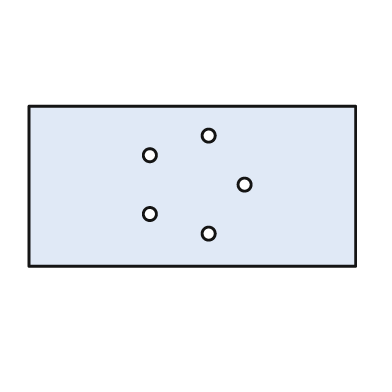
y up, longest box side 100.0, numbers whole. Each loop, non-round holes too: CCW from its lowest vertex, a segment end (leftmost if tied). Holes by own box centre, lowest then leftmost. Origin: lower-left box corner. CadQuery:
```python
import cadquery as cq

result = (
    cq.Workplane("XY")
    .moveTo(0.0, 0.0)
    .lineTo(100.0, 0.0)
    .lineTo(100.0, 49.0)
    .lineTo(0.0, 49.0)
    .close()
    .moveTo(55.0, 10.0)
    .circle(2.0)
    .moveTo(37.0, 16.0)
    .circle(2.0)
    .moveTo(66.0, 25.0)
    .circle(2.0)
    .moveTo(37.0, 34.0)
    .circle(2.0)
    .moveTo(55.0, 40.0)
    .circle(2.0)
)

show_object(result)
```